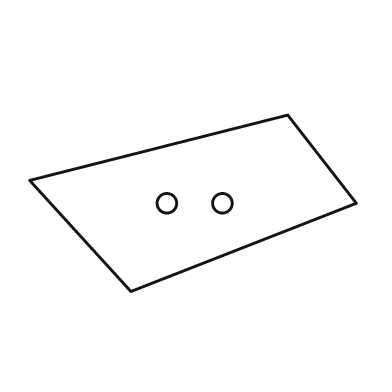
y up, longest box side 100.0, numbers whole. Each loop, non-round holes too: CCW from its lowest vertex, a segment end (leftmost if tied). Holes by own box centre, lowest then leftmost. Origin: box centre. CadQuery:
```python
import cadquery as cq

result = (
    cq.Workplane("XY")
    .moveTo(-19.0, -27.0)
    .lineTo(50.0, 0.0)
    .lineTo(29.0, 27.0)
    .lineTo(-50.0, 7.0)
    .close()
    .moveTo(-8.0, 0.0)
    .circle(3.0)
    .moveTo(9.0, 0.0)
    .circle(3.0)
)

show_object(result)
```